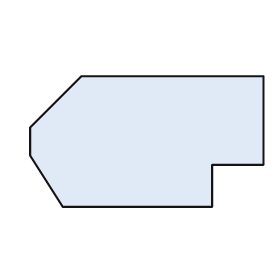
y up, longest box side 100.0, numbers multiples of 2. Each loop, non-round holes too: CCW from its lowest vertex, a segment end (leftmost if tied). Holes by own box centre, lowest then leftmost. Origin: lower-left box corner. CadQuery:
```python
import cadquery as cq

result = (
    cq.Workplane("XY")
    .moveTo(14.0, 0.0)
    .lineTo(78.0, 0.0)
    .lineTo(78.0, 18.0)
    .lineTo(100.0, 18.0)
    .lineTo(100.0, 56.0)
    .lineTo(22.0, 56.0)
    .lineTo(0.0, 34.0)
    .lineTo(0.0, 22.0)
    .close()
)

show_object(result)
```